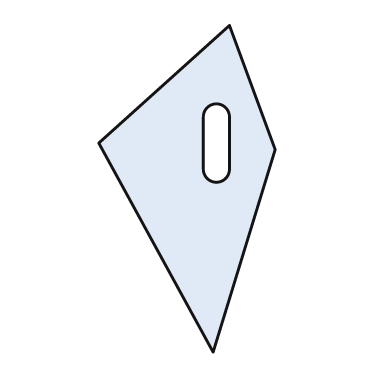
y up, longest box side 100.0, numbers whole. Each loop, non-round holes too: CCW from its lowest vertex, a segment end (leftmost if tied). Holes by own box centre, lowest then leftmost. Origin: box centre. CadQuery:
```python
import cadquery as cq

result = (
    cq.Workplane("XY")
    .moveTo(8.0, -50.0)
    .lineTo(27.0, 12.0)
    .lineTo(13.0, 50.0)
    .lineTo(-27.0, 14.0)
    .close()
    .moveTo(5.0, 6.0)
    .threePointArc((9.0, 2.0), (13.0, 6.0))
    .lineTo(13.0, 22.0)
    .threePointArc((9.0, 26.0), (5.0, 22.0))
    .close()
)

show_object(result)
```